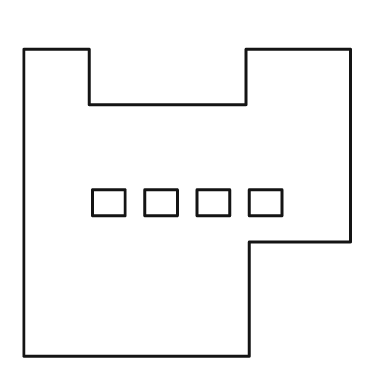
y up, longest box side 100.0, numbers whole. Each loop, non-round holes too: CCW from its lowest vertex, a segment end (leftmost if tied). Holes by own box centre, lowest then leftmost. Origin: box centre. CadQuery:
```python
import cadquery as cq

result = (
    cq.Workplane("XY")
    .moveTo(-50.0, -47.0)
    .lineTo(19.0, -47.0)
    .lineTo(19.0, -12.0)
    .lineTo(50.0, -12.0)
    .lineTo(50.0, 47.0)
    .lineTo(18.0, 47.0)
    .lineTo(18.0, 30.0)
    .lineTo(-30.0, 30.0)
    .lineTo(-30.0, 47.0)
    .lineTo(-50.0, 47.0)
    .close()
    .moveTo(-29.0, -4.0)
    .lineTo(-19.0, -4.0)
    .lineTo(-19.0, 4.0)
    .lineTo(-29.0, 4.0)
    .close()
    .moveTo(-13.0, -4.0)
    .lineTo(-3.0, -4.0)
    .lineTo(-3.0, 4.0)
    .lineTo(-13.0, 4.0)
    .close()
    .moveTo(3.0, -4.0)
    .lineTo(13.0, -4.0)
    .lineTo(13.0, 4.0)
    .lineTo(3.0, 4.0)
    .close()
    .moveTo(19.0, -4.0)
    .lineTo(29.0, -4.0)
    .lineTo(29.0, 4.0)
    .lineTo(19.0, 4.0)
    .close()
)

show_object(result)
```